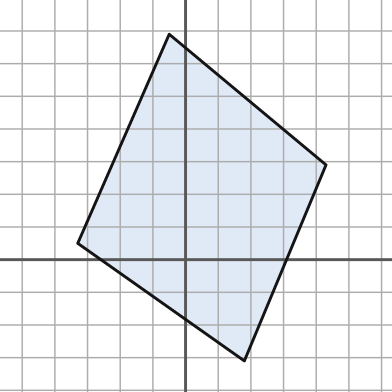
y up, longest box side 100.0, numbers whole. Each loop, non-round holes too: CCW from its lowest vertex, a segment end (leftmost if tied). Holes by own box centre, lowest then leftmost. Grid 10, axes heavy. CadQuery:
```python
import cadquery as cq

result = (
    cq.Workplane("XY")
    .moveTo(18.0, -31.0)
    .lineTo(43.0, 29.0)
    .lineTo(-5.0, 69.0)
    .lineTo(-33.0, 5.0)
    .close()
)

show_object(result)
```